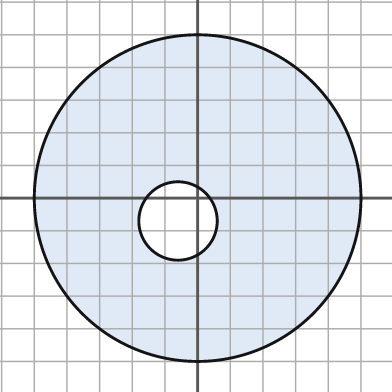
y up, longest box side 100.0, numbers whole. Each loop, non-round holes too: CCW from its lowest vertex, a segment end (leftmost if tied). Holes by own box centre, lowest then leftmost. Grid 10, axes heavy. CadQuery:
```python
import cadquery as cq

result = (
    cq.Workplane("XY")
    .moveTo(0.0, 0.0)
    .circle(50.0)
    .moveTo(-6.0, -7.0)
    .circle(12.0)
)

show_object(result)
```